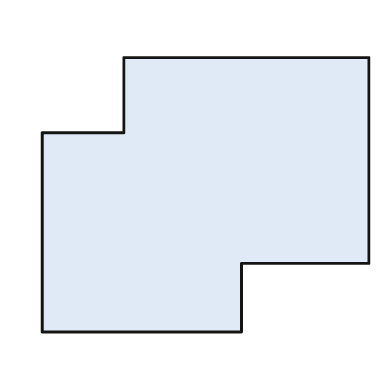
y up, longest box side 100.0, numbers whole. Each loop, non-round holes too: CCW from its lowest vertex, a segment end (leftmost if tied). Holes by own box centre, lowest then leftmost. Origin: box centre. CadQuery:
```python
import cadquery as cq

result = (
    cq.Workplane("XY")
    .moveTo(-50.0, -42.0)
    .lineTo(11.0, -42.0)
    .lineTo(11.0, -21.0)
    .lineTo(50.0, -21.0)
    .lineTo(50.0, 42.0)
    .lineTo(-25.0, 42.0)
    .lineTo(-25.0, 19.0)
    .lineTo(-50.0, 19.0)
    .close()
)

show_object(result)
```